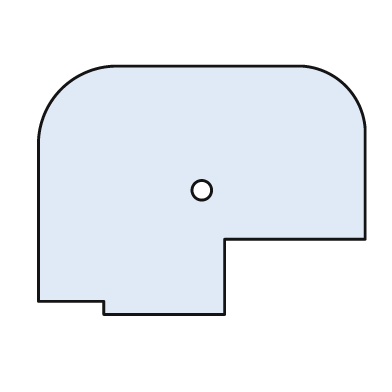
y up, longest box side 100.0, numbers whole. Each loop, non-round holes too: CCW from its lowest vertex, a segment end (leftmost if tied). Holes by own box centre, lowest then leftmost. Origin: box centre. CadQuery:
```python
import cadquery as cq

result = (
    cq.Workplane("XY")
    .moveTo(-30.0, -38.0)
    .lineTo(7.0, -38.0)
    .lineTo(7.0, -15.0)
    .lineTo(50.0, -15.0)
    .lineTo(50.0, 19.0)
    .threePointArc((44.0, 32.0), (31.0, 38.0))
    .lineTo(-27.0, 38.0)
    .threePointArc((-43.0, 31.0), (-50.0, 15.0))
    .lineTo(-50.0, -34.0)
    .lineTo(-30.0, -34.0)
    .close()
    .moveTo(0.0, 0.0)
    .circle(3.0)
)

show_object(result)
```